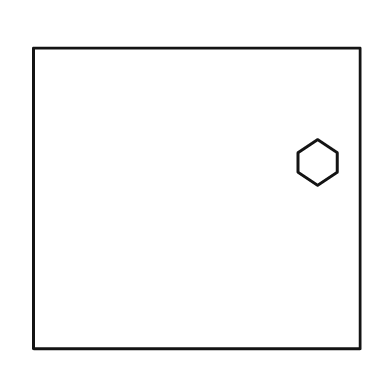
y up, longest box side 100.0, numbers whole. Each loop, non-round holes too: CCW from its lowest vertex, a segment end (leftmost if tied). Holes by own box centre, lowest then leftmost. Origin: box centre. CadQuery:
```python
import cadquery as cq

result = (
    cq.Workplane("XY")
    .moveTo(-50.0, -46.0)
    .lineTo(50.0, -46.0)
    .lineTo(50.0, 46.0)
    .lineTo(-50.0, 46.0)
    .close()
    .moveTo(37.0, 4.0)
    .lineTo(43.0, 8.0)
    .lineTo(43.0, 14.0)
    .lineTo(37.0, 18.0)
    .lineTo(31.0, 14.0)
    .lineTo(31.0, 8.0)
    .close()
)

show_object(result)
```